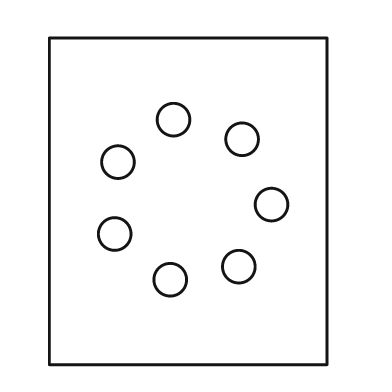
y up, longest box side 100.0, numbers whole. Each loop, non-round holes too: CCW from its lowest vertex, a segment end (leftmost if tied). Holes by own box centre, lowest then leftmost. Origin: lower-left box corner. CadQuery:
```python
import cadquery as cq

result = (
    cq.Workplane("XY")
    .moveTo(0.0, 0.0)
    .lineTo(85.0, 0.0)
    .lineTo(85.0, 100.0)
    .lineTo(0.0, 100.0)
    .close()
    .moveTo(37.0, 26.0)
    .circle(5.0)
    .moveTo(58.0, 30.0)
    .circle(5.0)
    .moveTo(20.0, 40.0)
    .circle(5.0)
    .moveTo(68.0, 49.0)
    .circle(5.0)
    .moveTo(21.0, 62.0)
    .circle(5.0)
    .moveTo(59.0, 69.0)
    .circle(5.0)
    .moveTo(38.0, 75.0)
    .circle(5.0)
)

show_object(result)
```